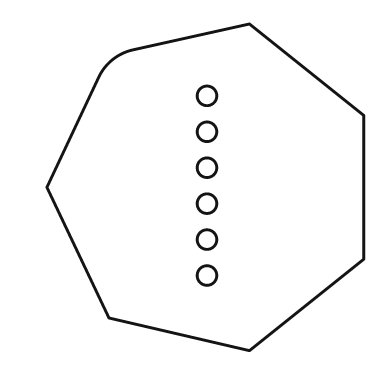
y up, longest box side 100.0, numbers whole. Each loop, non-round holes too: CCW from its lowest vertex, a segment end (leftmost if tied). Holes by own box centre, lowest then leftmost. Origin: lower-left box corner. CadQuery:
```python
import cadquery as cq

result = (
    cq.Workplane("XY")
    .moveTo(62.0, 0.0)
    .lineTo(97.0, 28.0)
    .lineTo(97.0, 72.0)
    .lineTo(62.0, 100.0)
    .lineTo(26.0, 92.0)
    .threePointArc((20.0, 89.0), (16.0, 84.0))
    .lineTo(0.0, 50.0)
    .lineTo(19.0, 10.0)
    .close()
    .moveTo(49.0, 23.0)
    .circle(3.0)
    .moveTo(49.0, 34.0)
    .circle(3.0)
    .moveTo(49.0, 45.0)
    .circle(3.0)
    .moveTo(49.0, 56.0)
    .circle(3.0)
    .moveTo(49.0, 67.0)
    .circle(3.0)
    .moveTo(49.0, 78.0)
    .circle(3.0)
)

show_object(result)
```